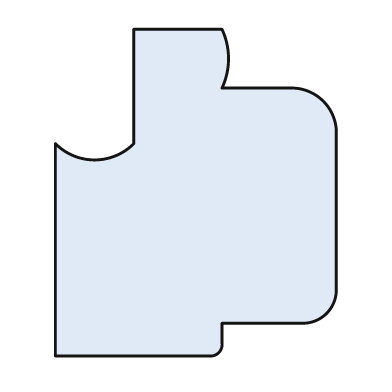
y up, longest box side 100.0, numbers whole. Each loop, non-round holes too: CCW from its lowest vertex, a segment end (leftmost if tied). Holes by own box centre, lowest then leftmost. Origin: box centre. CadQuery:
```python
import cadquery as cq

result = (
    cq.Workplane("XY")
    .moveTo(-43.0, -50.0)
    .lineTo(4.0, -50.0)
    .threePointArc((7.0, -49.0), (8.0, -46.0))
    .lineTo(8.0, -40.0)
    .lineTo(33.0, -40.0)
    .threePointArc((40.0, -37.0), (43.0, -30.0))
    .lineTo(43.0, 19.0)
    .threePointArc((39.0, 28.0), (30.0, 32.0))
    .lineTo(8.0, 32.0)
    .threePointArc((10.0, 41.0), (8.0, 50.0))
    .lineTo(-19.0, 50.0)
    .lineTo(-19.0, 15.0)
    .threePointArc((-31.0, 10.0), (-43.0, 15.0))
    .close()
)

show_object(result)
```